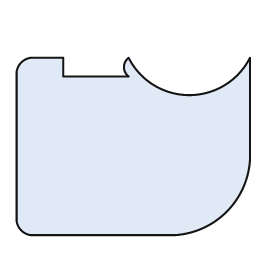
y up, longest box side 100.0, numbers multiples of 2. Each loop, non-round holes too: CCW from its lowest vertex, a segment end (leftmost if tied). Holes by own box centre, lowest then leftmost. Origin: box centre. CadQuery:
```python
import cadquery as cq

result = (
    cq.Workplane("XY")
    .moveTo(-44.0, -38.0)
    .lineTo(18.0, -38.0)
    .threePointArc((40.0, -28.0), (50.0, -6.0))
    .lineTo(50.0, 38.0)
    .threePointArc((24.0, 22.0), (-2.0, 38.0))
    .threePointArc((-4.0, 34.0), (-2.0, 30.0))
    .lineTo(-30.0, 30.0)
    .lineTo(-30.0, 38.0)
    .lineTo(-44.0, 38.0)
    .threePointArc((-48.0, 36.0), (-50.0, 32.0))
    .lineTo(-50.0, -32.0)
    .threePointArc((-48.0, -36.0), (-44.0, -38.0))
    .close()
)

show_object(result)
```